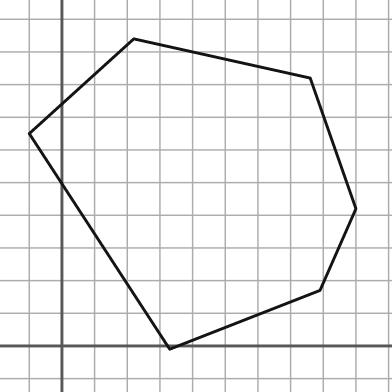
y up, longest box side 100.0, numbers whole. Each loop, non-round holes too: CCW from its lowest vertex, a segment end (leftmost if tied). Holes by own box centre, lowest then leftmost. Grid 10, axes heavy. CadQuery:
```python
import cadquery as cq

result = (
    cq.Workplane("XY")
    .moveTo(33.0, -1.0)
    .lineTo(79.0, 17.0)
    .lineTo(90.0, 42.0)
    .lineTo(76.0, 82.0)
    .lineTo(22.0, 94.0)
    .lineTo(-10.0, 65.0)
    .close()
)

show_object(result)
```